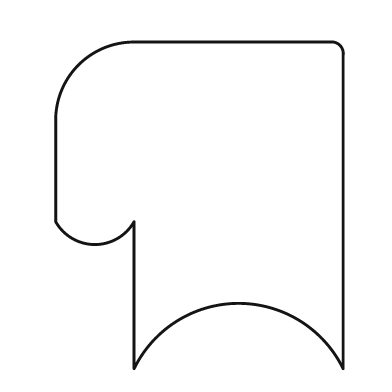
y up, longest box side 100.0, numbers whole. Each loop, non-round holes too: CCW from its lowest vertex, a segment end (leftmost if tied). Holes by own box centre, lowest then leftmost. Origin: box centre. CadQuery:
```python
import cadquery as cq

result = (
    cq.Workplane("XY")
    .moveTo(-20.0, -50.0)
    .threePointArc((12.0, -30.0), (44.0, -50.0))
    .lineTo(44.0, 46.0)
    .threePointArc((43.0, 49.0), (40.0, 50.0))
    .lineTo(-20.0, 50.0)
    .threePointArc((-37.0, 43.0), (-44.0, 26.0))
    .lineTo(-44.0, -5.0)
    .threePointArc((-32.0, -12.0), (-20.0, -5.0))
    .close()
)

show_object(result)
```